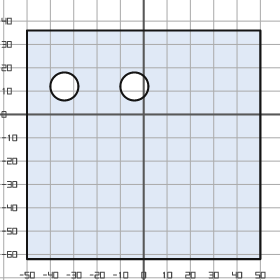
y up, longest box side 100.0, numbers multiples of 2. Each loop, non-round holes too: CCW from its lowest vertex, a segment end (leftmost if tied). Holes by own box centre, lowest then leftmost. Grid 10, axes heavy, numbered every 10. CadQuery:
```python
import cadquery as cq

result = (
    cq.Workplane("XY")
    .moveTo(-50.0, -62.0)
    .lineTo(50.0, -62.0)
    .lineTo(50.0, 36.0)
    .lineTo(-50.0, 36.0)
    .close()
    .moveTo(-34.0, 12.0)
    .circle(6.0)
    .moveTo(-4.0, 12.0)
    .circle(6.0)
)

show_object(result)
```